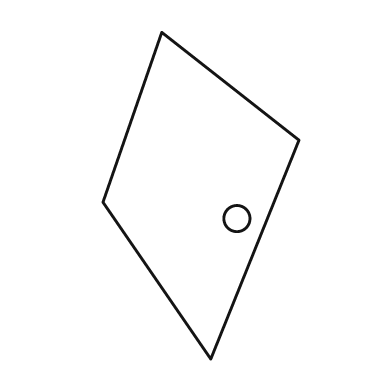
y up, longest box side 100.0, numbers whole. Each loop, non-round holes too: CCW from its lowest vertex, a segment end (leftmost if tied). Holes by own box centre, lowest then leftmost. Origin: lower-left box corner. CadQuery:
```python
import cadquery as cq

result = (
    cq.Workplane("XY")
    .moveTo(33.0, 0.0)
    .lineTo(60.0, 67.0)
    .lineTo(18.0, 100.0)
    .lineTo(0.0, 48.0)
    .close()
    .moveTo(41.0, 43.0)
    .circle(4.0)
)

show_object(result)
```